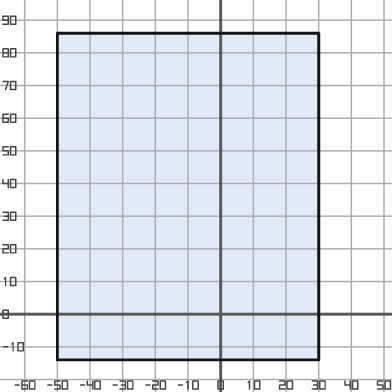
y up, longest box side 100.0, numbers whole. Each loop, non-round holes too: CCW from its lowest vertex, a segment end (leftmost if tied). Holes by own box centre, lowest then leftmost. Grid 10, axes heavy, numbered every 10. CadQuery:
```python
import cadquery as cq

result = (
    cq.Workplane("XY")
    .moveTo(-50.0, -14.0)
    .lineTo(30.0, -14.0)
    .lineTo(30.0, 86.0)
    .lineTo(-50.0, 86.0)
    .close()
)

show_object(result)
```